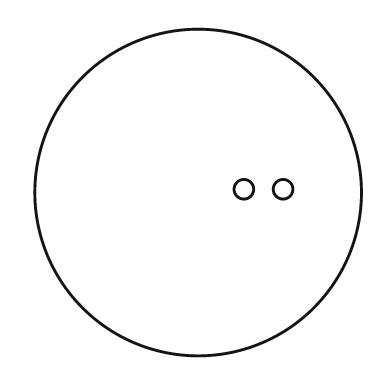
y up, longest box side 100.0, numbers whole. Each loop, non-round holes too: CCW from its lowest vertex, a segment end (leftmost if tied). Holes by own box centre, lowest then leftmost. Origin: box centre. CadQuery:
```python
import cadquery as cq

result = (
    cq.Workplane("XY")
    .moveTo(0.0, 0.0)
    .circle(50.0)
    .moveTo(14.0, 1.0)
    .circle(3.0)
    .moveTo(26.0, 1.0)
    .circle(3.0)
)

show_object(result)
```